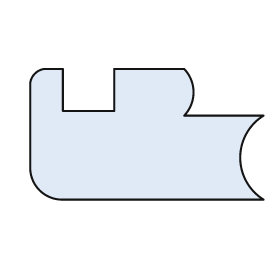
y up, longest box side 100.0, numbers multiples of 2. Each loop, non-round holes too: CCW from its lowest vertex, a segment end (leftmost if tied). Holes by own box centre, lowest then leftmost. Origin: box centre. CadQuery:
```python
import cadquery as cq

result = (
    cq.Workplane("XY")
    .moveTo(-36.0, -28.0)
    .lineTo(50.0, -28.0)
    .threePointArc((40.0, -10.0), (50.0, 8.0))
    .lineTo(16.0, 8.0)
    .threePointArc((20.0, 18.0), (16.0, 28.0))
    .lineTo(-14.0, 28.0)
    .lineTo(-14.0, 10.0)
    .lineTo(-36.0, 10.0)
    .lineTo(-36.0, 28.0)
    .lineTo(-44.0, 28.0)
    .threePointArc((-48.0, 26.0), (-50.0, 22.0))
    .lineTo(-50.0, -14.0)
    .threePointArc((-46.0, -24.0), (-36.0, -28.0))
    .close()
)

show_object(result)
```